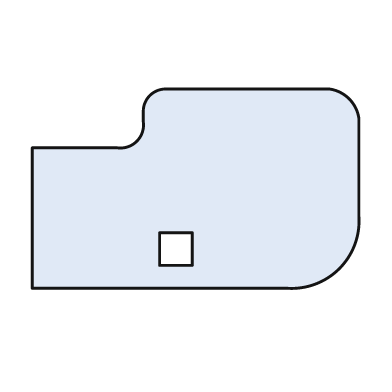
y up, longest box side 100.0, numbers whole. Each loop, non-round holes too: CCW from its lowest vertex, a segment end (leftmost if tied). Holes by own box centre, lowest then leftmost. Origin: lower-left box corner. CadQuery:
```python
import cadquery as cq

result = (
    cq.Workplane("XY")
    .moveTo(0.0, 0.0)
    .lineTo(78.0, 0.0)
    .threePointArc((94.0, 6.0), (100.0, 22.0))
    .lineTo(100.0, 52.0)
    .threePointArc((97.0, 58.0), (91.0, 61.0))
    .lineTo(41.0, 61.0)
    .threePointArc((36.0, 59.0), (34.0, 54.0))
    .lineTo(34.0, 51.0)
    .threePointArc((32.0, 45.0), (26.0, 43.0))
    .lineTo(0.0, 43.0)
    .close()
    .moveTo(39.0, 7.0)
    .lineTo(49.0, 7.0)
    .lineTo(49.0, 17.0)
    .lineTo(39.0, 17.0)
    .close()
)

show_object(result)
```